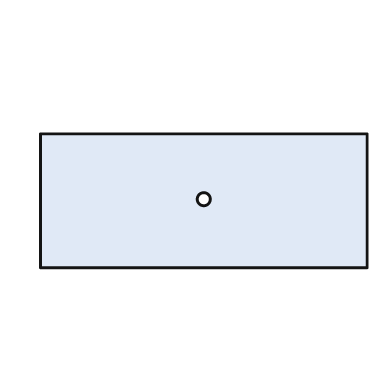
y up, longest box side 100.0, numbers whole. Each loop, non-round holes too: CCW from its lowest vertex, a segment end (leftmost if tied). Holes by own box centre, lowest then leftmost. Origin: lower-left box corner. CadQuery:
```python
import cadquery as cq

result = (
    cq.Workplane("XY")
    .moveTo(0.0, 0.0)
    .lineTo(100.0, 0.0)
    .lineTo(100.0, 41.0)
    .lineTo(0.0, 41.0)
    .close()
    .moveTo(50.0, 21.0)
    .circle(2.0)
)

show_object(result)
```